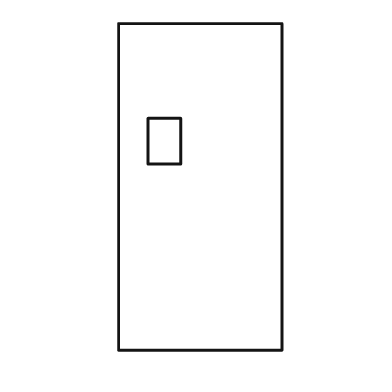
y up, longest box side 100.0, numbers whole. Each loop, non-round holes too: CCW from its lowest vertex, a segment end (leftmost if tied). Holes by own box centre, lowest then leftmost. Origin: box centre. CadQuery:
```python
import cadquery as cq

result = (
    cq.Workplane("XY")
    .moveTo(-25.0, -50.0)
    .lineTo(25.0, -50.0)
    .lineTo(25.0, 50.0)
    .lineTo(-25.0, 50.0)
    .close()
    .moveTo(-16.0, 7.0)
    .lineTo(-6.0, 7.0)
    .lineTo(-6.0, 21.0)
    .lineTo(-16.0, 21.0)
    .close()
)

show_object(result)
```